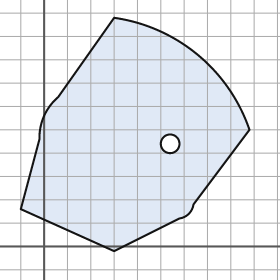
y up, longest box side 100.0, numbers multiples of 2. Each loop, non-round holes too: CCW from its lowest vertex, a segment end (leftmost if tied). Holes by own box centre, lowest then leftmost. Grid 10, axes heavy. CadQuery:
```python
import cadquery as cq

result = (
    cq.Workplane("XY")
    .moveTo(30.0, -2.0)
    .lineTo(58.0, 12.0)
    .threePointArc((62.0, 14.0), (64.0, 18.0))
    .lineTo(88.0, 50.0)
    .threePointArc((66.0, 82.0), (30.0, 98.0))
    .lineTo(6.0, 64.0)
    .threePointArc((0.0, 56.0), (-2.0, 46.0))
    .lineTo(-10.0, 16.0)
    .close()
    .moveTo(54.0, 44.0)
    .circle(4.0)
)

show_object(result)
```